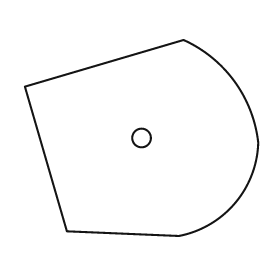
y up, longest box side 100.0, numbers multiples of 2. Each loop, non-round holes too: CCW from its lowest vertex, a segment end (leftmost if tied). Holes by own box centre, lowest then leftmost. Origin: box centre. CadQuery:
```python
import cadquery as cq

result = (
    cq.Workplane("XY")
    .moveTo(16.0, -42.0)
    .threePointArc((40.0, -28.0), (50.0, -2.0))
    .threePointArc((40.0, 24.0), (18.0, 42.0))
    .lineTo(-50.0, 22.0)
    .lineTo(-32.0, -40.0)
    .close()
    .moveTo(0.0, 0.0)
    .circle(4.0)
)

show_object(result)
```